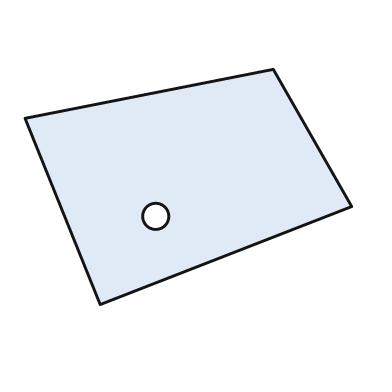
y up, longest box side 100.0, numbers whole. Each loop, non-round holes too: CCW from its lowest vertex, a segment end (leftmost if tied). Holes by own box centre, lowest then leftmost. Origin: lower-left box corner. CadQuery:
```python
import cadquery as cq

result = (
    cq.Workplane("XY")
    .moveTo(23.0, 0.0)
    .lineTo(100.0, 30.0)
    .lineTo(76.0, 72.0)
    .lineTo(0.0, 57.0)
    .close()
    .moveTo(40.0, 27.0)
    .circle(4.0)
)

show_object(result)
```